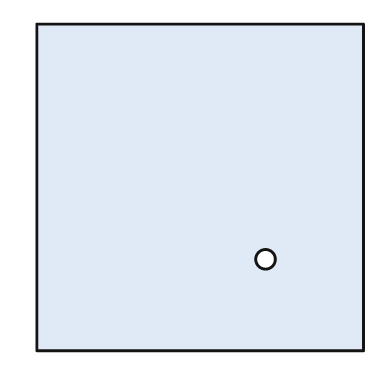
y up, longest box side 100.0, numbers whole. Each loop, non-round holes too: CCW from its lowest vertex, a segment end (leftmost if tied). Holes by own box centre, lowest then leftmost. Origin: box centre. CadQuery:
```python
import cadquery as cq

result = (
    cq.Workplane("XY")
    .moveTo(-50.0, -50.0)
    .lineTo(50.0, -50.0)
    .lineTo(50.0, 50.0)
    .lineTo(-50.0, 50.0)
    .close()
    .moveTo(20.0, -22.0)
    .circle(3.0)
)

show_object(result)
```